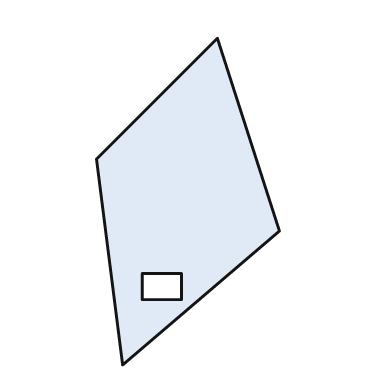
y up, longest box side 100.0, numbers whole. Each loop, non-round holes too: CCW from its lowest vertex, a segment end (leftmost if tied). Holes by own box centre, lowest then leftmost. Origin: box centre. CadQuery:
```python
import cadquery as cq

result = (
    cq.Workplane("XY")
    .moveTo(-20.0, -50.0)
    .lineTo(28.0, -9.0)
    .lineTo(9.0, 50.0)
    .lineTo(-28.0, 13.0)
    .close()
    .moveTo(-14.0, -30.0)
    .lineTo(-2.0, -30.0)
    .lineTo(-2.0, -22.0)
    .lineTo(-14.0, -22.0)
    .close()
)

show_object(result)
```